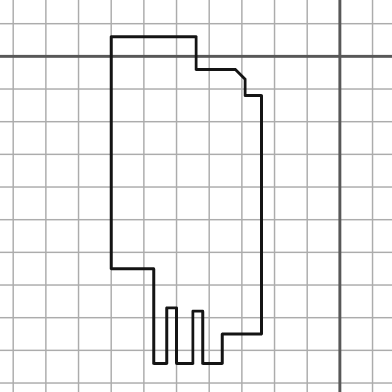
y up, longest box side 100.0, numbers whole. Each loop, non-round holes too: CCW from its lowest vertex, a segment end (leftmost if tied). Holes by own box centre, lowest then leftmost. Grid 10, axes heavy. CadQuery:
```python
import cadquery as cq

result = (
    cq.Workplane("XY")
    .moveTo(-57.0, -94.0)
    .lineTo(-53.0, -94.0)
    .lineTo(-53.0, -77.0)
    .lineTo(-50.0, -77.0)
    .lineTo(-50.0, -94.0)
    .lineTo(-45.0, -94.0)
    .lineTo(-45.0, -78.0)
    .lineTo(-42.0, -78.0)
    .lineTo(-42.0, -94.0)
    .lineTo(-36.0, -94.0)
    .lineTo(-36.0, -85.0)
    .lineTo(-24.0, -85.0)
    .lineTo(-24.0, -12.0)
    .lineTo(-29.0, -12.0)
    .lineTo(-29.0, -7.0)
    .lineTo(-32.0, -4.0)
    .lineTo(-44.0, -4.0)
    .lineTo(-44.0, 6.0)
    .lineTo(-70.0, 6.0)
    .lineTo(-70.0, -65.0)
    .lineTo(-57.0, -65.0)
    .close()
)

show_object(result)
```